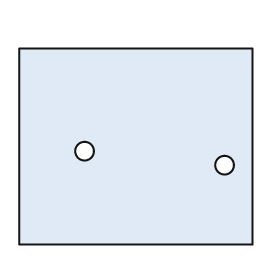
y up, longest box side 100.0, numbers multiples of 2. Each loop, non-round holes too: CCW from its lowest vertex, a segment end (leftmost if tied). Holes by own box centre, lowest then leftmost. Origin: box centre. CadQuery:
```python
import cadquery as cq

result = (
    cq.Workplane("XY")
    .moveTo(-50.0, -42.0)
    .lineTo(50.0, -42.0)
    .lineTo(50.0, 42.0)
    .lineTo(-50.0, 42.0)
    .close()
    .moveTo(38.0, -8.0)
    .circle(4.0)
    .moveTo(-22.0, -2.0)
    .circle(4.0)
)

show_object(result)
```